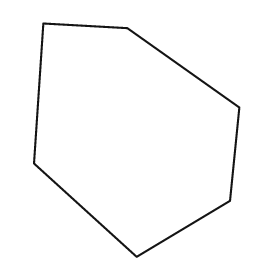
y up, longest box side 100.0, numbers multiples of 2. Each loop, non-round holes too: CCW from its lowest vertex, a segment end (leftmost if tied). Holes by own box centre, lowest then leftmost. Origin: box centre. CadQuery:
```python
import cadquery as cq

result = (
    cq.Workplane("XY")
    .moveTo(0.0, -50.0)
    .lineTo(40.0, -26.0)
    .lineTo(44.0, 14.0)
    .lineTo(-4.0, 48.0)
    .lineTo(-40.0, 50.0)
    .lineTo(-44.0, -10.0)
    .close()
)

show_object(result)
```